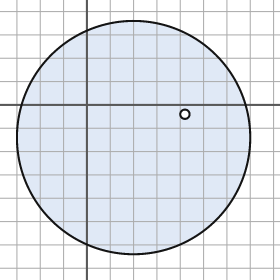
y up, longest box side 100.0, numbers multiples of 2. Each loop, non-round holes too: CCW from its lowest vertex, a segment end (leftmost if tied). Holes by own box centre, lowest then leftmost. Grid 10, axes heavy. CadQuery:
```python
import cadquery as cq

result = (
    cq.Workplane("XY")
    .moveTo(20.0, -14.0)
    .circle(50.0)
    .moveTo(42.0, -4.0)
    .circle(2.0)
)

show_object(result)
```